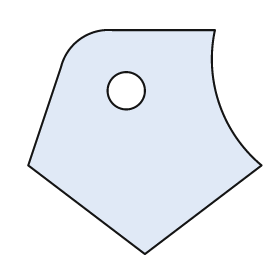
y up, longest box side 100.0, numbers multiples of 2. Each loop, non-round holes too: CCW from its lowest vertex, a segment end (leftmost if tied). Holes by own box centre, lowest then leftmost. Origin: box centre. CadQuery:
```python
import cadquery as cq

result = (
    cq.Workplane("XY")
    .moveTo(0.0, -48.0)
    .lineTo(50.0, -10.0)
    .threePointArc((32.0, 16.0), (30.0, 48.0))
    .lineTo(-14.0, 48.0)
    .threePointArc((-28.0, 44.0), (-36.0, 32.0))
    .lineTo(-50.0, -10.0)
    .close()
    .moveTo(-8.0, 22.0)
    .circle(8.0)
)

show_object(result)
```